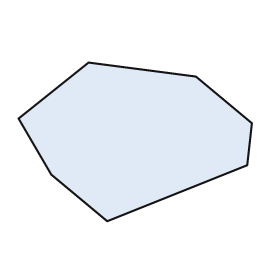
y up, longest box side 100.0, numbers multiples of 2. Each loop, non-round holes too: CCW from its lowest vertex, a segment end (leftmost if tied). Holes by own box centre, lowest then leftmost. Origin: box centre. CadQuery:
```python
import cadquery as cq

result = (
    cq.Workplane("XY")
    .moveTo(-12.0, -34.0)
    .lineTo(48.0, -10.0)
    .lineTo(50.0, 8.0)
    .lineTo(26.0, 28.0)
    .lineTo(-20.0, 34.0)
    .lineTo(-50.0, 10.0)
    .lineTo(-36.0, -14.0)
    .close()
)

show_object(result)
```